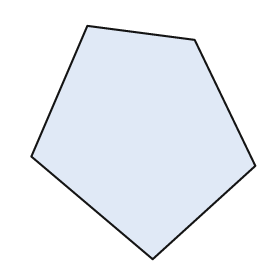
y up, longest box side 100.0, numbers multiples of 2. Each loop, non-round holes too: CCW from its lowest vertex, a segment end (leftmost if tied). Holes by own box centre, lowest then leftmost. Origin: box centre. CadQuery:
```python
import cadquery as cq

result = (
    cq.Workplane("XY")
    .moveTo(4.0, -50.0)
    .lineTo(48.0, -10.0)
    .lineTo(22.0, 44.0)
    .lineTo(-24.0, 50.0)
    .lineTo(-48.0, -6.0)
    .close()
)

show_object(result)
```